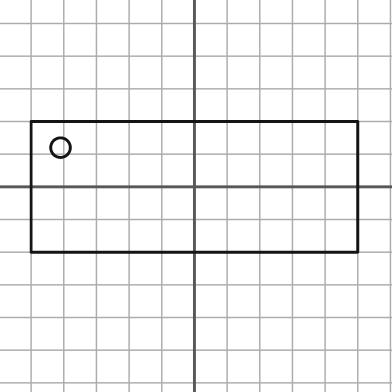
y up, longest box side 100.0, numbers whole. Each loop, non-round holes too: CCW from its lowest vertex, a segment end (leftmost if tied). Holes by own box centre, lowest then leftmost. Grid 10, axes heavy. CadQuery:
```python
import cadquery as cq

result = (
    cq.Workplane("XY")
    .moveTo(-50.0, -20.0)
    .lineTo(50.0, -20.0)
    .lineTo(50.0, 20.0)
    .lineTo(-50.0, 20.0)
    .close()
    .moveTo(-41.0, 12.0)
    .circle(3.0)
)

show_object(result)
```